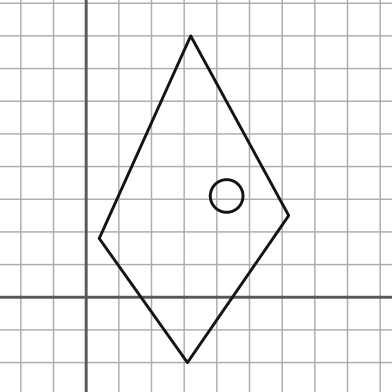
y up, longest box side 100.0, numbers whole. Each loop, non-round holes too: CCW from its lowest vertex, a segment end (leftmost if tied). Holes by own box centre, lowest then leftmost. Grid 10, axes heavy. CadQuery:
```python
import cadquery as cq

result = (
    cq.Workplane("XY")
    .moveTo(31.0, -20.0)
    .lineTo(62.0, 25.0)
    .lineTo(32.0, 80.0)
    .lineTo(4.0, 18.0)
    .close()
    .moveTo(43.0, 31.0)
    .circle(5.0)
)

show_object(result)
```